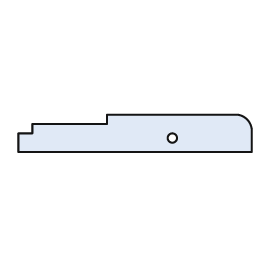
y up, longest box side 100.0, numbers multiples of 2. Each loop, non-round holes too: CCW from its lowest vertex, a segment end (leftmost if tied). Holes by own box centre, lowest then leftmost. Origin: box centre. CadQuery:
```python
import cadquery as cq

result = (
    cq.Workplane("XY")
    .moveTo(-50.0, -8.0)
    .lineTo(50.0, -8.0)
    .lineTo(50.0, 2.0)
    .threePointArc((48.0, 6.0), (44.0, 8.0))
    .lineTo(-12.0, 8.0)
    .lineTo(-12.0, 4.0)
    .lineTo(-44.0, 4.0)
    .lineTo(-44.0, 0.0)
    .lineTo(-50.0, 0.0)
    .close()
    .moveTo(16.0, -2.0)
    .circle(2.0)
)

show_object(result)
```